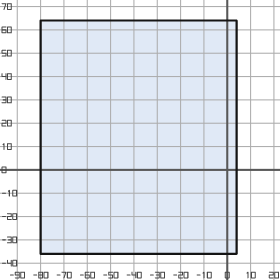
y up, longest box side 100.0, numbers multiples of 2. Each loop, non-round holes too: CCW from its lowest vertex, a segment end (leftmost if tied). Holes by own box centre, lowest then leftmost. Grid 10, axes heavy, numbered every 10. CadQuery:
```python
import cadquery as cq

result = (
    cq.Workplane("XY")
    .moveTo(-80.0, -36.0)
    .lineTo(4.0, -36.0)
    .lineTo(4.0, 64.0)
    .lineTo(-80.0, 64.0)
    .close()
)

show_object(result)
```